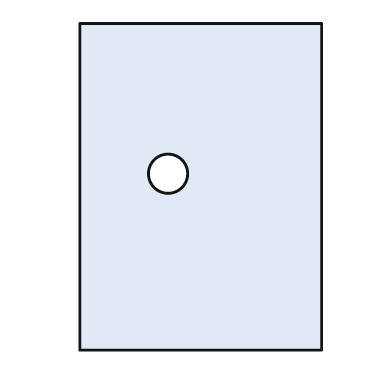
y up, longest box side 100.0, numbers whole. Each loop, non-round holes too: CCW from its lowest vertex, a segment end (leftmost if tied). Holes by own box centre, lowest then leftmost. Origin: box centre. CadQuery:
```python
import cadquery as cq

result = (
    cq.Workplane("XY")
    .moveTo(-37.0, -50.0)
    .lineTo(37.0, -50.0)
    .lineTo(37.0, 50.0)
    .lineTo(-37.0, 50.0)
    .close()
    .moveTo(-10.0, 4.0)
    .circle(6.0)
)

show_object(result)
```